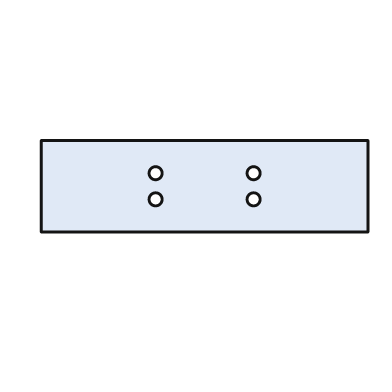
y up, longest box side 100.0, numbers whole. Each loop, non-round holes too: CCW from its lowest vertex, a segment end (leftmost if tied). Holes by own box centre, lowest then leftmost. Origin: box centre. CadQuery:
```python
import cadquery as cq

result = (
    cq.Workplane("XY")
    .moveTo(-50.0, -14.0)
    .lineTo(50.0, -14.0)
    .lineTo(50.0, 14.0)
    .lineTo(-50.0, 14.0)
    .close()
    .moveTo(-15.0, -4.0)
    .circle(2.0)
    .moveTo(15.0, -4.0)
    .circle(2.0)
    .moveTo(-15.0, 4.0)
    .circle(2.0)
    .moveTo(15.0, 4.0)
    .circle(2.0)
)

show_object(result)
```